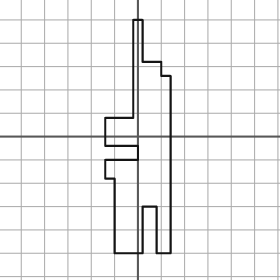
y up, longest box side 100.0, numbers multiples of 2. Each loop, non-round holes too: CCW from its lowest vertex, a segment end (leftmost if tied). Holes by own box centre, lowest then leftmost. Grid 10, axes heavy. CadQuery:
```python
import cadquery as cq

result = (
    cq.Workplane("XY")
    .moveTo(-10.0, -50.0)
    .lineTo(2.0, -50.0)
    .lineTo(2.0, -30.0)
    .lineTo(8.0, -30.0)
    .lineTo(8.0, -50.0)
    .lineTo(14.0, -50.0)
    .lineTo(14.0, 26.0)
    .lineTo(10.0, 26.0)
    .lineTo(10.0, 32.0)
    .lineTo(2.0, 32.0)
    .lineTo(2.0, 50.0)
    .lineTo(-2.0, 50.0)
    .lineTo(-2.0, 8.0)
    .lineTo(-14.0, 8.0)
    .lineTo(-14.0, -4.0)
    .lineTo(0.0, -4.0)
    .lineTo(0.0, -10.0)
    .lineTo(-14.0, -10.0)
    .lineTo(-14.0, -18.0)
    .lineTo(-10.0, -18.0)
    .close()
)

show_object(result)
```